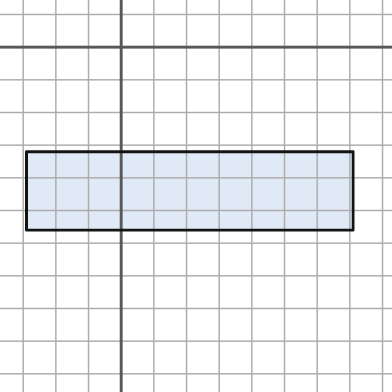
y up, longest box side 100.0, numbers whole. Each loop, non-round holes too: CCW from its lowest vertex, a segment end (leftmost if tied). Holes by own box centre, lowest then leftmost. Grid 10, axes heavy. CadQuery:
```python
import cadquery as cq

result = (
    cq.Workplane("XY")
    .moveTo(-29.0, -56.0)
    .lineTo(71.0, -56.0)
    .lineTo(71.0, -32.0)
    .lineTo(-29.0, -32.0)
    .close()
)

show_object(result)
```